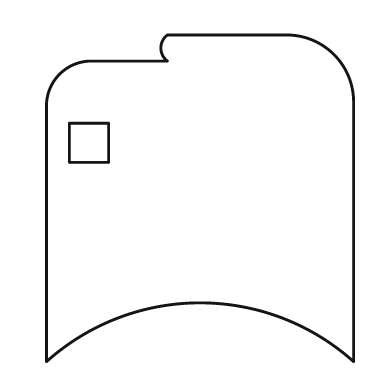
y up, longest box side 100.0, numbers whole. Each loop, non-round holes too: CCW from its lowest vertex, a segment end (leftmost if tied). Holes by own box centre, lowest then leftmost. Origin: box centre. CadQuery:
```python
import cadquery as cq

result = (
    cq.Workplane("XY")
    .moveTo(-47.0, -50.0)
    .threePointArc((0.0, -32.0), (47.0, -50.0))
    .lineTo(47.0, 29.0)
    .threePointArc((41.0, 44.0), (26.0, 50.0))
    .lineTo(-10.0, 50.0)
    .threePointArc((-12.0, 46.0), (-10.0, 42.0))
    .lineTo(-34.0, 42.0)
    .threePointArc((-43.0, 38.0), (-47.0, 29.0))
    .close()
    .moveTo(-40.0, 11.0)
    .lineTo(-28.0, 11.0)
    .lineTo(-28.0, 23.0)
    .lineTo(-40.0, 23.0)
    .close()
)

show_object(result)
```